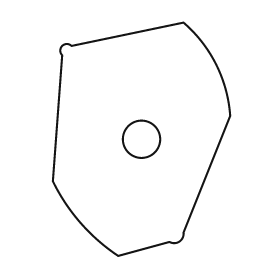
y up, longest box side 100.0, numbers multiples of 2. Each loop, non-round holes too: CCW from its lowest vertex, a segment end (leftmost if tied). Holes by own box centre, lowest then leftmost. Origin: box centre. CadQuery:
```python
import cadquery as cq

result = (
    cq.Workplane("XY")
    .moveTo(-10.0, -50.0)
    .lineTo(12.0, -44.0)
    .threePointArc((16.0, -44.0), (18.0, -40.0))
    .lineTo(38.0, 10.0)
    .threePointArc((32.0, 32.0), (18.0, 50.0))
    .lineTo(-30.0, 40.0)
    .threePointArc((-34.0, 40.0), (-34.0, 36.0))
    .lineTo(-38.0, -18.0)
    .threePointArc((-26.0, -36.0), (-10.0, -50.0))
    .close()
    .moveTo(0.0, 0.0)
    .circle(8.0)
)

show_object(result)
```